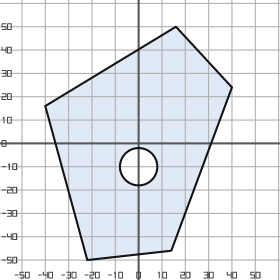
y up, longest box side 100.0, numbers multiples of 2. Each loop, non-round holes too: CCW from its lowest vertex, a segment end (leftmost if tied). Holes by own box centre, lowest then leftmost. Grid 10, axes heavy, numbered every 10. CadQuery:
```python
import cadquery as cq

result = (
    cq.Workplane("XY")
    .moveTo(-22.0, -50.0)
    .lineTo(14.0, -46.0)
    .lineTo(40.0, 24.0)
    .lineTo(16.0, 50.0)
    .lineTo(-40.0, 16.0)
    .close()
    .moveTo(0.0, -10.0)
    .circle(8.0)
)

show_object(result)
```